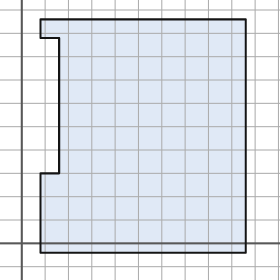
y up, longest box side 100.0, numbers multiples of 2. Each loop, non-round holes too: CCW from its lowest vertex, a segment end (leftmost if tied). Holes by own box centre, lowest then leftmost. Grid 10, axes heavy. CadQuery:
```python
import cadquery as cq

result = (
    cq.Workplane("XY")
    .moveTo(8.0, -4.0)
    .lineTo(96.0, -4.0)
    .lineTo(96.0, 96.0)
    .lineTo(8.0, 96.0)
    .lineTo(8.0, 88.0)
    .lineTo(16.0, 88.0)
    .lineTo(16.0, 30.0)
    .lineTo(8.0, 30.0)
    .close()
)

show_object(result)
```